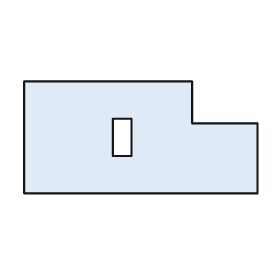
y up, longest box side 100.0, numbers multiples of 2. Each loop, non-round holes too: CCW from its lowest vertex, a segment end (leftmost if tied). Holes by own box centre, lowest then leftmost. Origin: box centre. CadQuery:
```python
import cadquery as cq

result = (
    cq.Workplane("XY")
    .moveTo(-50.0, -24.0)
    .lineTo(50.0, -24.0)
    .lineTo(50.0, 6.0)
    .lineTo(22.0, 6.0)
    .lineTo(22.0, 24.0)
    .lineTo(-50.0, 24.0)
    .close()
    .moveTo(-12.0, -8.0)
    .lineTo(-4.0, -8.0)
    .lineTo(-4.0, 8.0)
    .lineTo(-12.0, 8.0)
    .close()
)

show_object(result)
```